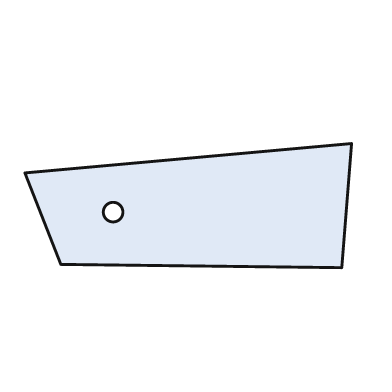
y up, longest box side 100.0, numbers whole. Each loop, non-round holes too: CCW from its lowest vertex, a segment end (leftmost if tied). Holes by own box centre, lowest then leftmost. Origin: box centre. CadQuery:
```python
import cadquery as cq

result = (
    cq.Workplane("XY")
    .moveTo(47.0, -19.0)
    .lineTo(50.0, 19.0)
    .lineTo(-50.0, 10.0)
    .lineTo(-39.0, -18.0)
    .close()
    .moveTo(-23.0, -2.0)
    .circle(3.0)
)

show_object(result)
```